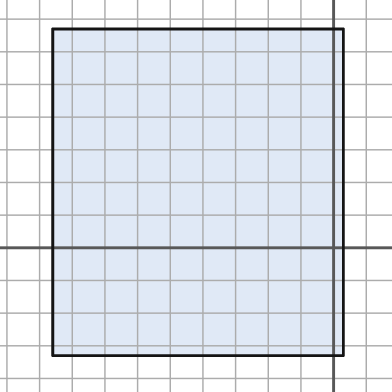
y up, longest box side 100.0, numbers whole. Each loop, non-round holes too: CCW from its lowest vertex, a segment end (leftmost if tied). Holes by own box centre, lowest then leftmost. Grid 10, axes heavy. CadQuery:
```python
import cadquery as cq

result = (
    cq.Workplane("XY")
    .moveTo(-86.0, -33.0)
    .lineTo(3.0, -33.0)
    .lineTo(3.0, 67.0)
    .lineTo(-86.0, 67.0)
    .close()
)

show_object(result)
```